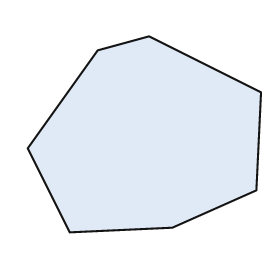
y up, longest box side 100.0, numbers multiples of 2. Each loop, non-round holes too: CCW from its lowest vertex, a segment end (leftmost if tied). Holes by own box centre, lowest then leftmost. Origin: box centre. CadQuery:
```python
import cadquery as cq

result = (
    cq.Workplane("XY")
    .moveTo(-32.0, -42.0)
    .lineTo(12.0, -40.0)
    .lineTo(48.0, -24.0)
    .lineTo(50.0, 18.0)
    .lineTo(2.0, 42.0)
    .lineTo(-20.0, 36.0)
    .lineTo(-50.0, -6.0)
    .close()
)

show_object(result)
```